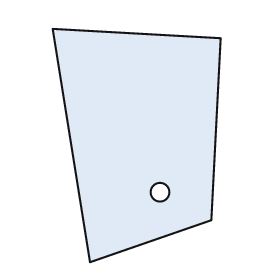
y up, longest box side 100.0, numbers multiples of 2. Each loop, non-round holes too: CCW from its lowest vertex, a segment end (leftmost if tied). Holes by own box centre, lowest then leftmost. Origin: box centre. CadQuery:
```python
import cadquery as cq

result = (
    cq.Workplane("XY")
    .moveTo(-20.0, -50.0)
    .lineTo(32.0, -32.0)
    .lineTo(36.0, 46.0)
    .lineTo(-36.0, 50.0)
    .close()
    .moveTo(10.0, -20.0)
    .circle(4.0)
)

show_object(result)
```